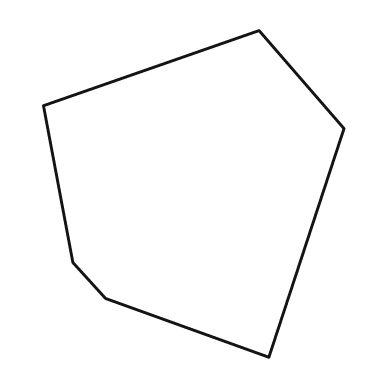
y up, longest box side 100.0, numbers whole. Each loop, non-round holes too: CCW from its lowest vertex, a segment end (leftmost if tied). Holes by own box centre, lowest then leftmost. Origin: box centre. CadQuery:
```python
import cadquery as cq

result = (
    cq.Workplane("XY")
    .moveTo(23.0, -50.0)
    .lineTo(46.0, 20.0)
    .lineTo(20.0, 50.0)
    .lineTo(-46.0, 27.0)
    .lineTo(-37.0, -21.0)
    .lineTo(-27.0, -32.0)
    .close()
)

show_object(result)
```